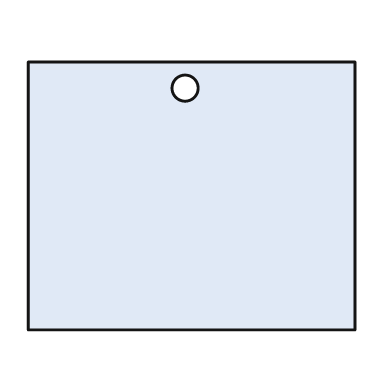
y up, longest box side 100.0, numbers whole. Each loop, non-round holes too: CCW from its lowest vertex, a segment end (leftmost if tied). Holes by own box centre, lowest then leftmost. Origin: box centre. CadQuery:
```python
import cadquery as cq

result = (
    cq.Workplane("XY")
    .moveTo(-50.0, -41.0)
    .lineTo(50.0, -41.0)
    .lineTo(50.0, 41.0)
    .lineTo(-50.0, 41.0)
    .close()
    .moveTo(-2.0, 33.0)
    .circle(4.0)
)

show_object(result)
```